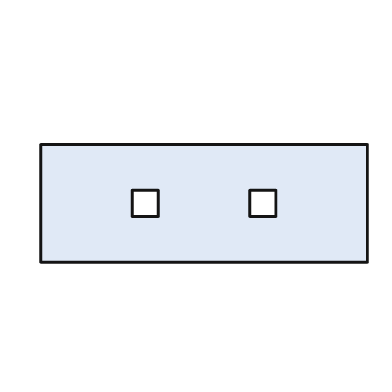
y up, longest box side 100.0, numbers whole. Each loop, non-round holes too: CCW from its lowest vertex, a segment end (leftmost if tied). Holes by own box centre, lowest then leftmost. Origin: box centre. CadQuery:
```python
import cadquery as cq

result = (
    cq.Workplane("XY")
    .moveTo(-50.0, -18.0)
    .lineTo(50.0, -18.0)
    .lineTo(50.0, 18.0)
    .lineTo(-50.0, 18.0)
    .close()
    .moveTo(-22.0, -4.0)
    .lineTo(-14.0, -4.0)
    .lineTo(-14.0, 4.0)
    .lineTo(-22.0, 4.0)
    .close()
    .moveTo(14.0, -4.0)
    .lineTo(22.0, -4.0)
    .lineTo(22.0, 4.0)
    .lineTo(14.0, 4.0)
    .close()
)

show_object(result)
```